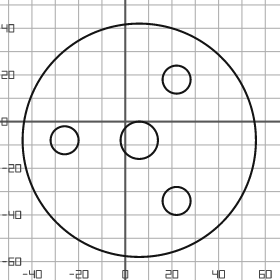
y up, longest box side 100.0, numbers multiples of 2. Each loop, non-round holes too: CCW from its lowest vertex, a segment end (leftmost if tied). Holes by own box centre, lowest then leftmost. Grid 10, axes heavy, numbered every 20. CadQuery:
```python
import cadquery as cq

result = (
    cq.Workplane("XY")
    .moveTo(6.0, -8.0)
    .circle(50.0)
    .moveTo(22.0, -34.0)
    .circle(6.0)
    .moveTo(-26.0, -8.0)
    .circle(6.0)
    .moveTo(6.0, -8.0)
    .circle(8.0)
    .moveTo(22.0, 18.0)
    .circle(6.0)
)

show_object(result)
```